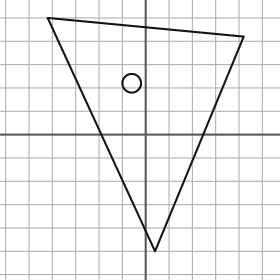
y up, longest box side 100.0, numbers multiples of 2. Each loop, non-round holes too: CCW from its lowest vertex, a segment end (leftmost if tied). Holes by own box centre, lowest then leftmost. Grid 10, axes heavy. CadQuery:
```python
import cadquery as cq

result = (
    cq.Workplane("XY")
    .moveTo(4.0, -50.0)
    .lineTo(42.0, 42.0)
    .lineTo(-42.0, 50.0)
    .close()
    .moveTo(-6.0, 22.0)
    .circle(4.0)
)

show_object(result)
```